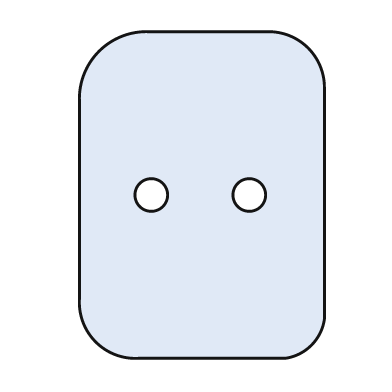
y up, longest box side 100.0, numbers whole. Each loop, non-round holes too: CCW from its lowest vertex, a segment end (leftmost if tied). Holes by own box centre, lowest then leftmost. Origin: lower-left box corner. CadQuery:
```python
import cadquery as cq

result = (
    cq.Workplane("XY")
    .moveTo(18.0, 0.0)
    .lineTo(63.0, 0.0)
    .threePointArc((71.0, 4.0), (75.0, 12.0))
    .lineTo(75.0, 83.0)
    .threePointArc((70.0, 95.0), (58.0, 100.0))
    .lineTo(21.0, 100.0)
    .threePointArc((6.0, 94.0), (0.0, 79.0))
    .lineTo(0.0, 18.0)
    .threePointArc((5.0, 5.0), (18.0, 0.0))
    .close()
    .moveTo(22.0, 50.0)
    .circle(5.0)
    .moveTo(52.0, 50.0)
    .circle(5.0)
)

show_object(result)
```